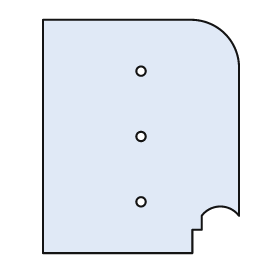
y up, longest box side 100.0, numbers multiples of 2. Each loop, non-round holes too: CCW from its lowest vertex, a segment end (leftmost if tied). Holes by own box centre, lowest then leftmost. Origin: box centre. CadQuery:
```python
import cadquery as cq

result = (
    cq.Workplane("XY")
    .moveTo(-42.0, -50.0)
    .lineTo(22.0, -50.0)
    .lineTo(22.0, -40.0)
    .lineTo(26.0, -40.0)
    .lineTo(26.0, -34.0)
    .threePointArc((34.0, -30.0), (42.0, -34.0))
    .lineTo(42.0, 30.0)
    .threePointArc((36.0, 44.0), (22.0, 50.0))
    .lineTo(-42.0, 50.0)
    .close()
    .moveTo(0.0, -28.0)
    .circle(2.0)
    .moveTo(0.0, 0.0)
    .circle(2.0)
    .moveTo(0.0, 28.0)
    .circle(2.0)
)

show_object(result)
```